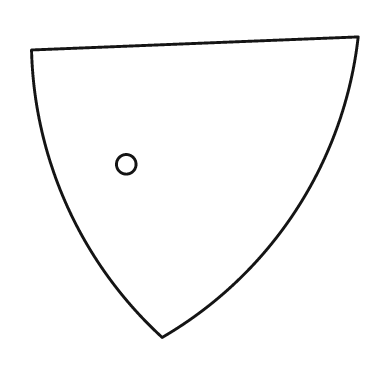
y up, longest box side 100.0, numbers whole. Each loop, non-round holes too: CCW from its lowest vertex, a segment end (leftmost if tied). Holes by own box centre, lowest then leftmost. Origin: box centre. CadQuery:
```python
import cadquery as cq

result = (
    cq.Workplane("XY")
    .moveTo(-10.0, -46.0)
    .threePointArc((31.0, -7.0), (50.0, 46.0))
    .lineTo(-50.0, 42.0)
    .threePointArc((-39.0, -6.0), (-10.0, -46.0))
    .close()
    .moveTo(-21.0, 7.0)
    .circle(3.0)
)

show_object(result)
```